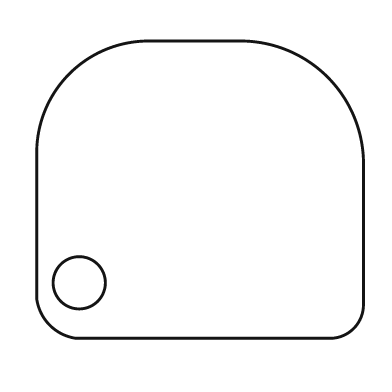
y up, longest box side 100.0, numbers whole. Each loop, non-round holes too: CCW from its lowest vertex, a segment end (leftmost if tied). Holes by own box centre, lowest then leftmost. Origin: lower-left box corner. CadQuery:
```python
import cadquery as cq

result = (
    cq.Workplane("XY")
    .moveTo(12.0, 0.0)
    .lineTo(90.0, 0.0)
    .threePointArc((97.0, 3.0), (100.0, 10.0))
    .lineTo(100.0, 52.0)
    .threePointArc((89.0, 80.0), (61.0, 91.0))
    .lineTo(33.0, 91.0)
    .threePointArc((10.0, 81.0), (0.0, 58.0))
    .lineTo(0.0, 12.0)
    .threePointArc((4.0, 4.0), (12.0, 0.0))
    .close()
    .moveTo(13.0, 17.0)
    .circle(8.0)
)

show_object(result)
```